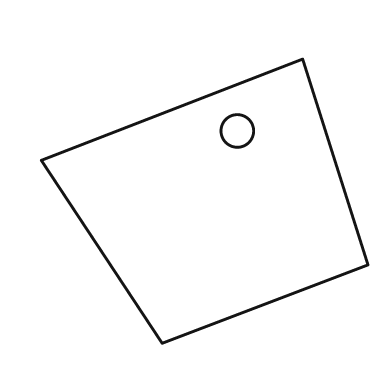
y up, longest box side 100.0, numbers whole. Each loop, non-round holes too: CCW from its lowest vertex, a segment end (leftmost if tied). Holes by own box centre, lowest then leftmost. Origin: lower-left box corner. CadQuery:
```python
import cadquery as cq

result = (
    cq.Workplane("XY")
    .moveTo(37.0, 0.0)
    .lineTo(100.0, 24.0)
    .lineTo(80.0, 87.0)
    .lineTo(0.0, 56.0)
    .close()
    .moveTo(60.0, 65.0)
    .circle(5.0)
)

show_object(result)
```